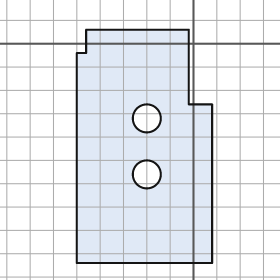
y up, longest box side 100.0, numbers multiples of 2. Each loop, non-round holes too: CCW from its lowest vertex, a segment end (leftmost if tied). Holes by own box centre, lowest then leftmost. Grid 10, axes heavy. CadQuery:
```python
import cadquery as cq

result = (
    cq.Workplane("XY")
    .moveTo(-50.0, -94.0)
    .lineTo(8.0, -94.0)
    .lineTo(8.0, -26.0)
    .lineTo(-2.0, -26.0)
    .lineTo(-2.0, 6.0)
    .lineTo(-46.0, 6.0)
    .lineTo(-46.0, -4.0)
    .lineTo(-50.0, -4.0)
    .close()
    .moveTo(-20.0, -56.0)
    .circle(6.0)
    .moveTo(-20.0, -32.0)
    .circle(6.0)
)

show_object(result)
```